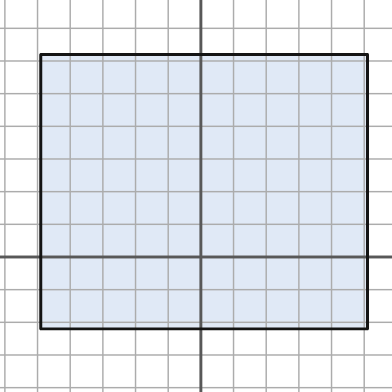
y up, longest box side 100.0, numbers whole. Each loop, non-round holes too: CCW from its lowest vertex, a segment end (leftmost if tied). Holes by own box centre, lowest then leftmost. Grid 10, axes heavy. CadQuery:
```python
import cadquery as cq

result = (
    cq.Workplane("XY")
    .moveTo(-49.0, -22.0)
    .lineTo(51.0, -22.0)
    .lineTo(51.0, 62.0)
    .lineTo(-49.0, 62.0)
    .close()
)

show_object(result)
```